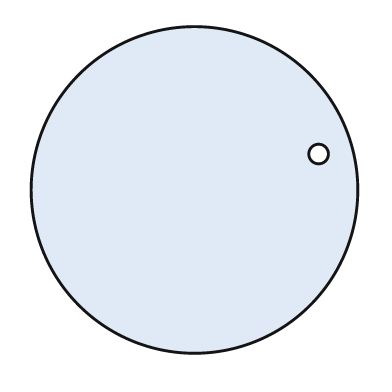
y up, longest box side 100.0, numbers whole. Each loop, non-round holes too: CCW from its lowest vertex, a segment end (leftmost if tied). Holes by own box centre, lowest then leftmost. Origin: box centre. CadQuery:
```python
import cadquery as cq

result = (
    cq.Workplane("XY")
    .moveTo(0.0, 0.0)
    .circle(50.0)
    .moveTo(38.0, 11.0)
    .circle(3.0)
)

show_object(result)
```